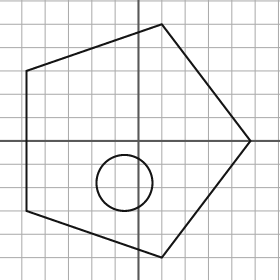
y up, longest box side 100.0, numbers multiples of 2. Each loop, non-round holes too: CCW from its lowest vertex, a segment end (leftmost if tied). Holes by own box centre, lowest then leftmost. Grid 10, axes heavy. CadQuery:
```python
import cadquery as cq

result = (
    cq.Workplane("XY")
    .moveTo(10.0, -50.0)
    .lineTo(48.0, 0.0)
    .lineTo(10.0, 50.0)
    .lineTo(-48.0, 30.0)
    .lineTo(-48.0, -30.0)
    .close()
    .moveTo(-6.0, -18.0)
    .circle(12.0)
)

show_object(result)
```